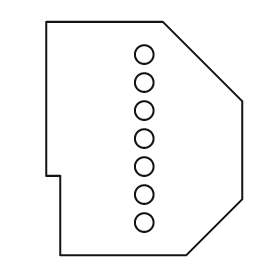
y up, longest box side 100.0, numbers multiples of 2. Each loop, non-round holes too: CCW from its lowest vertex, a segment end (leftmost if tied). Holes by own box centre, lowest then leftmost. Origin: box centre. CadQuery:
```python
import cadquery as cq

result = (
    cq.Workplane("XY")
    .moveTo(-36.0, -50.0)
    .lineTo(18.0, -50.0)
    .lineTo(42.0, -26.0)
    .lineTo(42.0, 16.0)
    .lineTo(8.0, 50.0)
    .lineTo(-42.0, 50.0)
    .lineTo(-42.0, -16.0)
    .lineTo(-36.0, -16.0)
    .close()
    .moveTo(0.0, -36.0)
    .circle(4.0)
    .moveTo(0.0, -24.0)
    .circle(4.0)
    .moveTo(0.0, -12.0)
    .circle(4.0)
    .moveTo(0.0, 0.0)
    .circle(4.0)
    .moveTo(0.0, 12.0)
    .circle(4.0)
    .moveTo(0.0, 24.0)
    .circle(4.0)
    .moveTo(0.0, 36.0)
    .circle(4.0)
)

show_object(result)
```